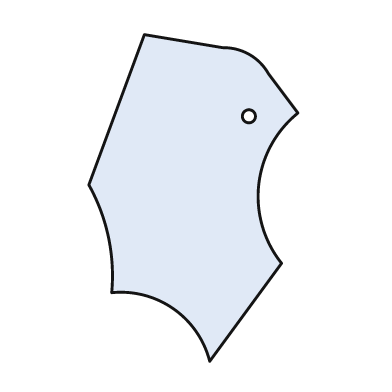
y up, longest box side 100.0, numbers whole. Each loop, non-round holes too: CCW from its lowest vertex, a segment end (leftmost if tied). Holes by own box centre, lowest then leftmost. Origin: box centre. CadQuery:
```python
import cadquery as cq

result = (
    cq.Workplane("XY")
    .moveTo(5.0, -50.0)
    .lineTo(27.0, -20.0)
    .threePointArc((20.0, 4.0), (32.0, 26.0))
    .lineTo(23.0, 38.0)
    .threePointArc((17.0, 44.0), (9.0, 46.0))
    .lineTo(-15.0, 50.0)
    .lineTo(-32.0, 4.0)
    .threePointArc((-26.0, -12.0), (-25.0, -29.0))
    .threePointArc((-6.0, -34.0), (5.0, -50.0))
    .close()
    .moveTo(17.0, 25.0)
    .circle(2.0)
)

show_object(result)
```